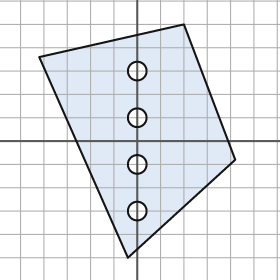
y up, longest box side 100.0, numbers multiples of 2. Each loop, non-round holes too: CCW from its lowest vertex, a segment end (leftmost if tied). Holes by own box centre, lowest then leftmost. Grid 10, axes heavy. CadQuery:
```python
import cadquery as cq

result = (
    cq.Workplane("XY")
    .moveTo(-4.0, -50.0)
    .lineTo(42.0, -8.0)
    .lineTo(20.0, 50.0)
    .lineTo(-42.0, 36.0)
    .close()
    .moveTo(0.0, -30.0)
    .circle(4.0)
    .moveTo(0.0, -10.0)
    .circle(4.0)
    .moveTo(0.0, 10.0)
    .circle(4.0)
    .moveTo(0.0, 30.0)
    .circle(4.0)
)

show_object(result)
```